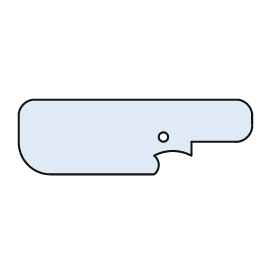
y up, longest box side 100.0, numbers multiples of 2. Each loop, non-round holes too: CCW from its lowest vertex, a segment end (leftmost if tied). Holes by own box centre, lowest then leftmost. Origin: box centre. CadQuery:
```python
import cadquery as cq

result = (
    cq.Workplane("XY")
    .moveTo(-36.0, -16.0)
    .lineTo(8.0, -16.0)
    .threePointArc((10.0, -12.0), (8.0, -8.0))
    .threePointArc((16.0, -6.0), (24.0, -8.0))
    .lineTo(24.0, -2.0)
    .lineTo(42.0, -2.0)
    .threePointArc((48.0, 0.0), (50.0, 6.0))
    .lineTo(50.0, 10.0)
    .threePointArc((48.0, 14.0), (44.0, 16.0))
    .lineTo(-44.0, 16.0)
    .threePointArc((-48.0, 14.0), (-50.0, 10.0))
    .lineTo(-50.0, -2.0)
    .threePointArc((-46.0, -12.0), (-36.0, -16.0))
    .close()
    .moveTo(12.0, 0.0)
    .circle(2.0)
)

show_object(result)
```